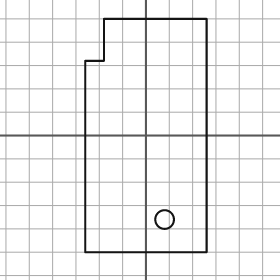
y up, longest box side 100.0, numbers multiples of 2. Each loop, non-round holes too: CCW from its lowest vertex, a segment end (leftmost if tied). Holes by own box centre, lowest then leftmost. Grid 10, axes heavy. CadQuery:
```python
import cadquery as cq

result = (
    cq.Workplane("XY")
    .moveTo(-26.0, -50.0)
    .lineTo(26.0, -50.0)
    .lineTo(26.0, 50.0)
    .lineTo(-18.0, 50.0)
    .lineTo(-18.0, 32.0)
    .lineTo(-26.0, 32.0)
    .close()
    .moveTo(8.0, -36.0)
    .circle(4.0)
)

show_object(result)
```